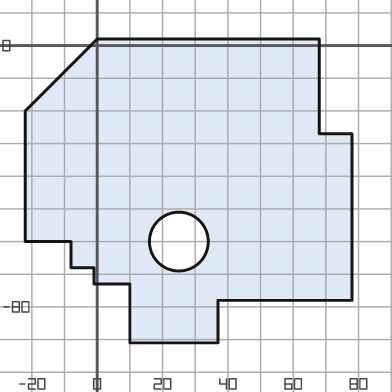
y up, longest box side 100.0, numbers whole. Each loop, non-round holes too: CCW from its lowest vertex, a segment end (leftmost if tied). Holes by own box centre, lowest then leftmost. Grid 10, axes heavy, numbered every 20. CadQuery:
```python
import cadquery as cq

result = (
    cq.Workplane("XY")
    .moveTo(10.0, -91.0)
    .lineTo(37.0, -91.0)
    .lineTo(37.0, -78.0)
    .lineTo(78.0, -78.0)
    .lineTo(78.0, -27.0)
    .lineTo(68.0, -27.0)
    .lineTo(68.0, 2.0)
    .lineTo(0.0, 2.0)
    .lineTo(-22.0, -20.0)
    .lineTo(-22.0, -60.0)
    .lineTo(-8.0, -60.0)
    .lineTo(-8.0, -68.0)
    .lineTo(-1.0, -68.0)
    .lineTo(-1.0, -73.0)
    .lineTo(10.0, -73.0)
    .close()
    .moveTo(25.0, -60.0)
    .circle(9.0)
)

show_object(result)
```